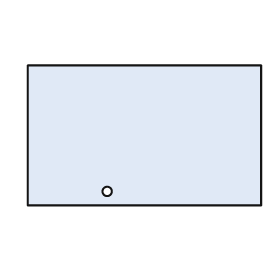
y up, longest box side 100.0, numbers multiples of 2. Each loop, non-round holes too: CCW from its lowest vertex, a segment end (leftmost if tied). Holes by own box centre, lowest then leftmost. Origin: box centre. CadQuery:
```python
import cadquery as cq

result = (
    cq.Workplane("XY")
    .moveTo(-50.0, -30.0)
    .lineTo(50.0, -30.0)
    .lineTo(50.0, 30.0)
    .lineTo(-50.0, 30.0)
    .close()
    .moveTo(-16.0, -24.0)
    .circle(2.0)
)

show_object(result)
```